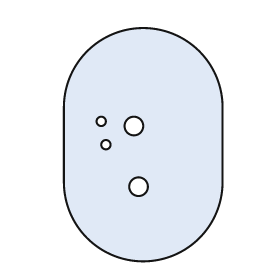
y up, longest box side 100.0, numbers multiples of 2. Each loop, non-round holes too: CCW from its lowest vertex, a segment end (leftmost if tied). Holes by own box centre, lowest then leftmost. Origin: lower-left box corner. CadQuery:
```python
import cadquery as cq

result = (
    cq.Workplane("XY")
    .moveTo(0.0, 34.0)
    .threePointArc((34.0, 0.0), (68.0, 34.0))
    .lineTo(68.0, 66.0)
    .threePointArc((34.0, 100.0), (0.0, 66.0))
    .close()
    .moveTo(32.0, 32.0)
    .circle(4.0)
    .moveTo(18.0, 50.0)
    .circle(2.0)
    .moveTo(30.0, 58.0)
    .circle(4.0)
    .moveTo(16.0, 60.0)
    .circle(2.0)
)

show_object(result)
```